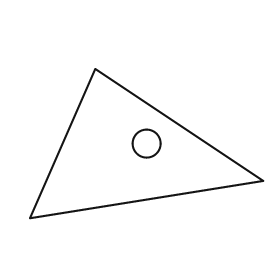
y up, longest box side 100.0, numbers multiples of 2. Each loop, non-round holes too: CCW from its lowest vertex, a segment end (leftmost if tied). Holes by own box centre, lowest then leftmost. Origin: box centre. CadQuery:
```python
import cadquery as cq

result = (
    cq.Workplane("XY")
    .moveTo(-50.0, -32.0)
    .lineTo(50.0, -16.0)
    .lineTo(-22.0, 32.0)
    .close()
    .moveTo(0.0, 0.0)
    .circle(6.0)
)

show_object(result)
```